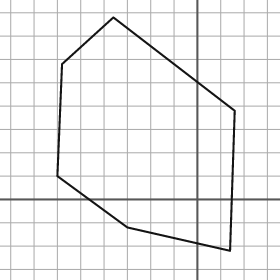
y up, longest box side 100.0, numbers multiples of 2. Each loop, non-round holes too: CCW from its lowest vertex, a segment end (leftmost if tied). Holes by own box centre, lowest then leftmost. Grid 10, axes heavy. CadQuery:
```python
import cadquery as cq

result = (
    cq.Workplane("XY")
    .moveTo(14.0, -22.0)
    .lineTo(16.0, 38.0)
    .lineTo(-36.0, 78.0)
    .lineTo(-58.0, 58.0)
    .lineTo(-60.0, 10.0)
    .lineTo(-30.0, -12.0)
    .close()
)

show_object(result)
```